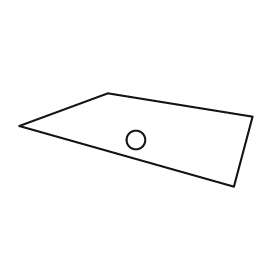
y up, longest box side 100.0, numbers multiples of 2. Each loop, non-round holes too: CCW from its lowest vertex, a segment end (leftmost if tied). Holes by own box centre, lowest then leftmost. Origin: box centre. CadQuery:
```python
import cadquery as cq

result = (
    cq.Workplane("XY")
    .moveTo(42.0, -20.0)
    .lineTo(50.0, 10.0)
    .lineTo(-12.0, 20.0)
    .lineTo(-50.0, 6.0)
    .close()
    .moveTo(0.0, 0.0)
    .circle(4.0)
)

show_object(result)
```